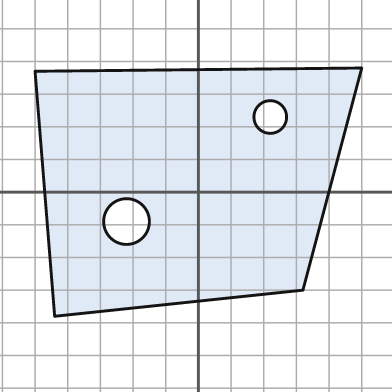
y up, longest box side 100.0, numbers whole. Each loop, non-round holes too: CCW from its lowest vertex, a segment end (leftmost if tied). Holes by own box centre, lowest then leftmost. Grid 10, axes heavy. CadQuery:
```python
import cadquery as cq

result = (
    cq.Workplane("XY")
    .moveTo(-44.0, -38.0)
    .lineTo(32.0, -30.0)
    .lineTo(50.0, 38.0)
    .lineTo(-50.0, 37.0)
    .close()
    .moveTo(-22.0, -9.0)
    .circle(7.0)
    .moveTo(22.0, 23.0)
    .circle(5.0)
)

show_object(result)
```